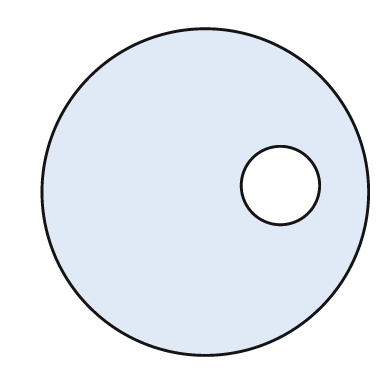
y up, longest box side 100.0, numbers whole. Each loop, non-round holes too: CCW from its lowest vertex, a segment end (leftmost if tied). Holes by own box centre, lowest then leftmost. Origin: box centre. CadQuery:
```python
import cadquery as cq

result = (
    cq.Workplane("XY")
    .moveTo(0.0, 0.0)
    .circle(50.0)
    .moveTo(23.0, 2.0)
    .circle(12.0)
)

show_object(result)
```